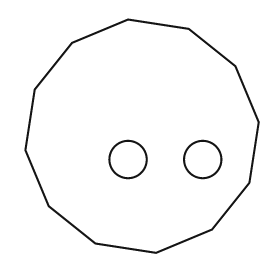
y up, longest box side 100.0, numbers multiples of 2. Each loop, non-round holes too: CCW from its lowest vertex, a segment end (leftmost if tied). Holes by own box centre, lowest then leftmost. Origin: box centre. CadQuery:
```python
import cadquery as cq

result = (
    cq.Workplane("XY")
    .moveTo(6.0, -50.0)
    .lineTo(30.0, -40.0)
    .lineTo(46.0, -20.0)
    .lineTo(50.0, 6.0)
    .lineTo(40.0, 30.0)
    .lineTo(20.0, 46.0)
    .lineTo(-6.0, 50.0)
    .lineTo(-30.0, 40.0)
    .lineTo(-46.0, 20.0)
    .lineTo(-50.0, -6.0)
    .lineTo(-40.0, -30.0)
    .lineTo(-20.0, -46.0)
    .close()
    .moveTo(-6.0, -10.0)
    .circle(8.0)
    .moveTo(26.0, -10.0)
    .circle(8.0)
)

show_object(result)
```